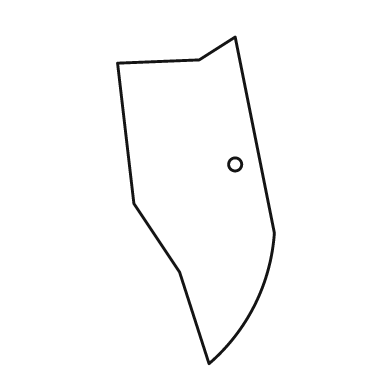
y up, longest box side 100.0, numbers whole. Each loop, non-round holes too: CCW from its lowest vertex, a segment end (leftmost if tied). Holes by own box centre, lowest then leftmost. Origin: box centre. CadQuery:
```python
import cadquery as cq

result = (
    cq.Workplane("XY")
    .moveTo(4.0, -50.0)
    .threePointArc((18.0, -32.0), (24.0, -10.0))
    .lineTo(12.0, 50.0)
    .lineTo(1.0, 43.0)
    .lineTo(-24.0, 42.0)
    .lineTo(-19.0, -1.0)
    .lineTo(-5.0, -22.0)
    .close()
    .moveTo(12.0, 11.0)
    .circle(2.0)
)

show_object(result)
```